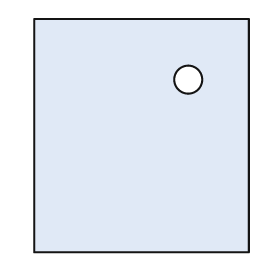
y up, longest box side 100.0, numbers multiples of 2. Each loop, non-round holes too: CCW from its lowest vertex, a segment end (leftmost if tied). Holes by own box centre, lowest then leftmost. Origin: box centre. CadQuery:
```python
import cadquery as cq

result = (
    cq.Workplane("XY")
    .moveTo(-46.0, -50.0)
    .lineTo(46.0, -50.0)
    .lineTo(46.0, 50.0)
    .lineTo(-46.0, 50.0)
    .close()
    .moveTo(20.0, 24.0)
    .circle(6.0)
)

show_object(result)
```